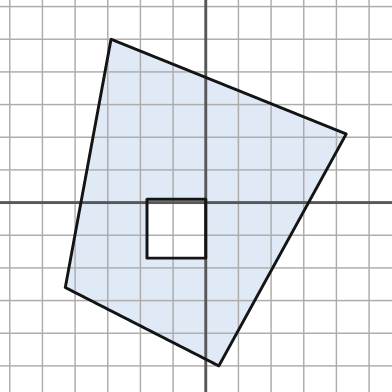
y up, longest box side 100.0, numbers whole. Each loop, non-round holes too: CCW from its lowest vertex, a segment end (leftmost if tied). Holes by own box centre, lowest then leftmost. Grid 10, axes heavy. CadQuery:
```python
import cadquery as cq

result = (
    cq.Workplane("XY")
    .moveTo(4.0, -50.0)
    .lineTo(43.0, 21.0)
    .lineTo(-29.0, 50.0)
    .lineTo(-43.0, -26.0)
    .close()
    .moveTo(-18.0, -17.0)
    .lineTo(0.0, -17.0)
    .lineTo(0.0, 1.0)
    .lineTo(-18.0, 1.0)
    .close()
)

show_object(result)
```